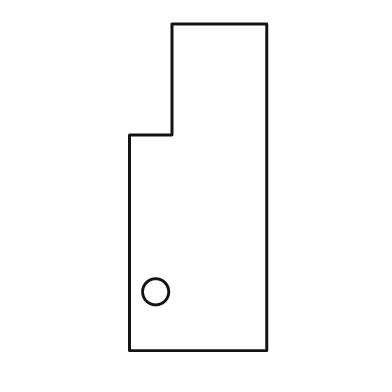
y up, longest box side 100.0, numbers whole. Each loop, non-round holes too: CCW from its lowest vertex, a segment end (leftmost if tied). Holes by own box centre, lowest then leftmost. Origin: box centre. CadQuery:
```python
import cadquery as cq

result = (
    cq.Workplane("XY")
    .moveTo(-21.0, -50.0)
    .lineTo(21.0, -50.0)
    .lineTo(21.0, 50.0)
    .lineTo(-8.0, 50.0)
    .lineTo(-8.0, 16.0)
    .lineTo(-21.0, 16.0)
    .close()
    .moveTo(-13.0, -32.0)
    .circle(4.0)
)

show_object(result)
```